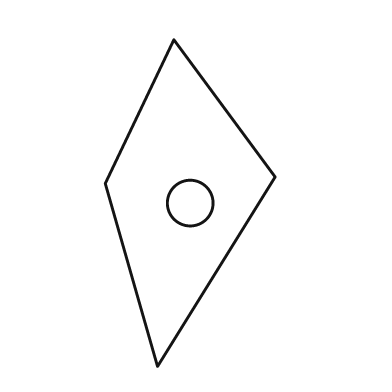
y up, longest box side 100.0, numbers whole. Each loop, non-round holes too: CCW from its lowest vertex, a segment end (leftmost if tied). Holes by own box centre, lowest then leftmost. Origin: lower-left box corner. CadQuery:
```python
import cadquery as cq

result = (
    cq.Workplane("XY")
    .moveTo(16.0, 0.0)
    .lineTo(52.0, 58.0)
    .lineTo(21.0, 100.0)
    .lineTo(0.0, 56.0)
    .close()
    .moveTo(26.0, 50.0)
    .circle(7.0)
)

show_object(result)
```